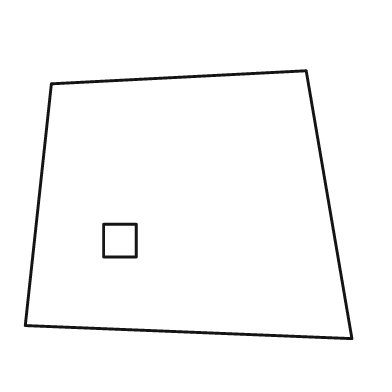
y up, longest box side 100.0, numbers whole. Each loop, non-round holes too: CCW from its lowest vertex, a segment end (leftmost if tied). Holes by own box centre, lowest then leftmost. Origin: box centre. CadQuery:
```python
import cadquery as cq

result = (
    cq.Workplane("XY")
    .moveTo(50.0, -41.0)
    .lineTo(36.0, 41.0)
    .lineTo(-42.0, 37.0)
    .lineTo(-50.0, -37.0)
    .close()
    .moveTo(-26.0, -16.0)
    .lineTo(-16.0, -16.0)
    .lineTo(-16.0, -6.0)
    .lineTo(-26.0, -6.0)
    .close()
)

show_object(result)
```